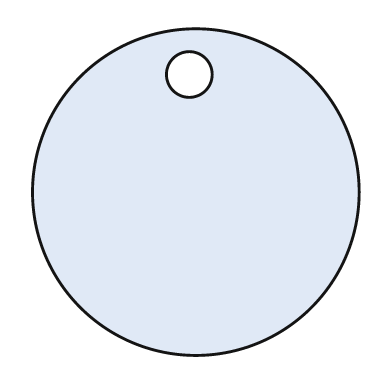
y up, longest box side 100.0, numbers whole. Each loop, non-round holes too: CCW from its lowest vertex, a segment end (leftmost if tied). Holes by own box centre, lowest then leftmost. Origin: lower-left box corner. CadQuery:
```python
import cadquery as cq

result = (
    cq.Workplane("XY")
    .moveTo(50.0, 50.0)
    .circle(50.0)
    .moveTo(48.0, 86.0)
    .circle(7.0)
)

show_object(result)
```